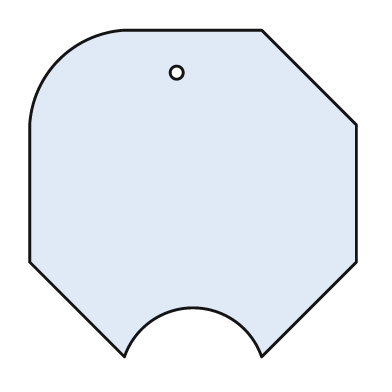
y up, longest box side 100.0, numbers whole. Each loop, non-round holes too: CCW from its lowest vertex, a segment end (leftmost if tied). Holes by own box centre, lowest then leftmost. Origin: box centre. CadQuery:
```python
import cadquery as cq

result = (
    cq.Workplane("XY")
    .moveTo(-21.0, -50.0)
    .threePointArc((0.0, -35.0), (21.0, -50.0))
    .lineTo(50.0, -21.0)
    .lineTo(50.0, 21.0)
    .lineTo(21.0, 50.0)
    .lineTo(-21.0, 50.0)
    .threePointArc((-41.0, 41.0), (-50.0, 21.0))
    .lineTo(-50.0, -21.0)
    .close()
    .moveTo(-5.0, 37.0)
    .circle(2.0)
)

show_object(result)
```